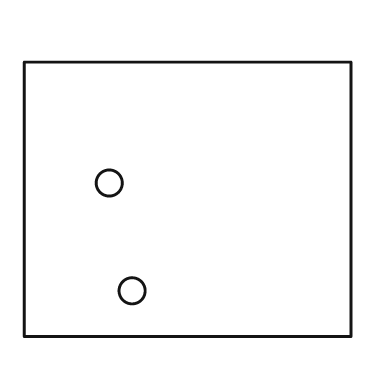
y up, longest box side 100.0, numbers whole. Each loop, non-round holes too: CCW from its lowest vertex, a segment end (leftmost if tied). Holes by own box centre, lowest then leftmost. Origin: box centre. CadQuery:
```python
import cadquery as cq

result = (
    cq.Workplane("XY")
    .moveTo(-50.0, -42.0)
    .lineTo(50.0, -42.0)
    .lineTo(50.0, 42.0)
    .lineTo(-50.0, 42.0)
    .close()
    .moveTo(-17.0, -28.0)
    .circle(4.0)
    .moveTo(-24.0, 5.0)
    .circle(4.0)
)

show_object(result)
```